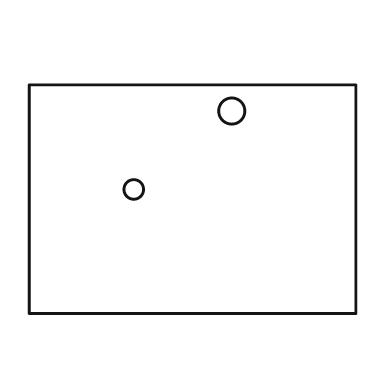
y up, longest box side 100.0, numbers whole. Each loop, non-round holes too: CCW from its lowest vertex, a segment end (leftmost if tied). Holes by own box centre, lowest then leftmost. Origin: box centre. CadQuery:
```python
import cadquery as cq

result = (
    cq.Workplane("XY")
    .moveTo(-50.0, -35.0)
    .lineTo(50.0, -35.0)
    .lineTo(50.0, 35.0)
    .lineTo(-50.0, 35.0)
    .close()
    .moveTo(-18.0, 3.0)
    .circle(3.0)
    .moveTo(12.0, 27.0)
    .circle(4.0)
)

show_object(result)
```